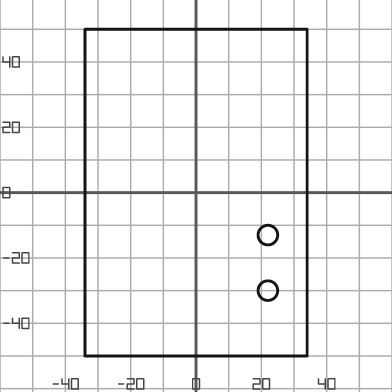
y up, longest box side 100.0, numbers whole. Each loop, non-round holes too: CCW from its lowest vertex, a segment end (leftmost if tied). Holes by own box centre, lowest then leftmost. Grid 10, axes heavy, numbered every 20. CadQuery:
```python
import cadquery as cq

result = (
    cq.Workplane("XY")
    .moveTo(-34.0, -50.0)
    .lineTo(34.0, -50.0)
    .lineTo(34.0, 50.0)
    .lineTo(-34.0, 50.0)
    .close()
    .moveTo(22.0, -30.0)
    .circle(3.0)
    .moveTo(22.0, -13.0)
    .circle(3.0)
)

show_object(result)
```